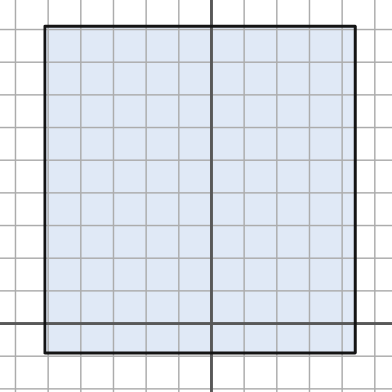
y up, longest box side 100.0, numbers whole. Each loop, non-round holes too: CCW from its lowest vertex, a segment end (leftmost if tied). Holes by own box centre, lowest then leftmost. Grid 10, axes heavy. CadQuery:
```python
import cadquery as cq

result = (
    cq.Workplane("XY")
    .moveTo(-51.0, -9.0)
    .lineTo(44.0, -9.0)
    .lineTo(44.0, 91.0)
    .lineTo(-51.0, 91.0)
    .close()
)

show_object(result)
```